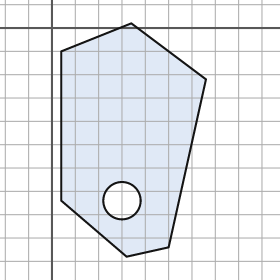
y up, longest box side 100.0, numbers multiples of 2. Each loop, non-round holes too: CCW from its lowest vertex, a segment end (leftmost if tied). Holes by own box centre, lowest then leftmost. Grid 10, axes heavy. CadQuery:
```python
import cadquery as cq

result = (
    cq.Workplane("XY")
    .moveTo(32.0, -98.0)
    .lineTo(50.0, -94.0)
    .lineTo(66.0, -22.0)
    .lineTo(34.0, 2.0)
    .lineTo(4.0, -10.0)
    .lineTo(4.0, -74.0)
    .close()
    .moveTo(30.0, -74.0)
    .circle(8.0)
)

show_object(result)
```